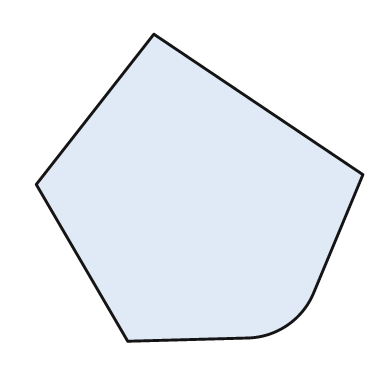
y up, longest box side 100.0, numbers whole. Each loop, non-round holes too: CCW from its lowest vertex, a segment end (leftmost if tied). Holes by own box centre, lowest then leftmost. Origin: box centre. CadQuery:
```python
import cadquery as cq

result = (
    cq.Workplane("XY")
    .moveTo(-22.0, -47.0)
    .lineTo(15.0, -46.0)
    .threePointArc((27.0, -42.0), (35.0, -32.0))
    .lineTo(50.0, 4.0)
    .lineTo(-14.0, 47.0)
    .lineTo(-50.0, 1.0)
    .close()
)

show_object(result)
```